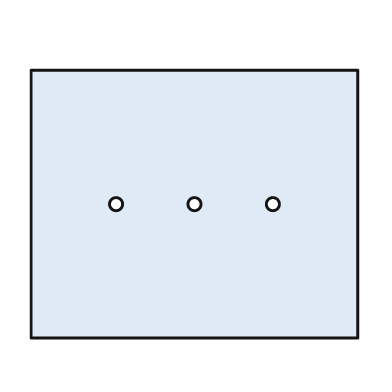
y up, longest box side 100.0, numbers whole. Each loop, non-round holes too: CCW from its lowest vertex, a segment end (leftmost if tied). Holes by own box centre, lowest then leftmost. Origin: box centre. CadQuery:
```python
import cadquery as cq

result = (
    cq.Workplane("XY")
    .moveTo(-50.0, -41.0)
    .lineTo(50.0, -41.0)
    .lineTo(50.0, 41.0)
    .lineTo(-50.0, 41.0)
    .close()
    .moveTo(-24.0, 0.0)
    .circle(2.0)
    .moveTo(0.0, 0.0)
    .circle(2.0)
    .moveTo(24.0, 0.0)
    .circle(2.0)
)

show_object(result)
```